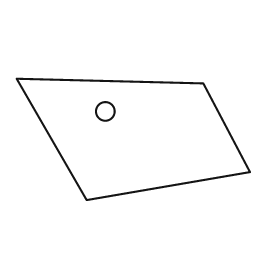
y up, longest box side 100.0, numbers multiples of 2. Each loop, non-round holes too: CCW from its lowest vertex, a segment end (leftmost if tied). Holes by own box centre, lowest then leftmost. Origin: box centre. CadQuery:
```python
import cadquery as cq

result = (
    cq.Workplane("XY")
    .moveTo(-20.0, -26.0)
    .lineTo(50.0, -14.0)
    .lineTo(30.0, 24.0)
    .lineTo(-50.0, 26.0)
    .close()
    .moveTo(-12.0, 12.0)
    .circle(4.0)
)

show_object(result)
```